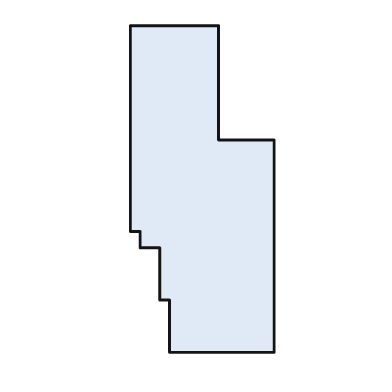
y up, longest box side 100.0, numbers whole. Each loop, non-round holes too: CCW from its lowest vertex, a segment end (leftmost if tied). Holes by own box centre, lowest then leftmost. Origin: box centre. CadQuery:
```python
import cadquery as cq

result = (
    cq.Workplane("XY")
    .moveTo(-10.0, -50.0)
    .lineTo(22.0, -50.0)
    .lineTo(22.0, 15.0)
    .lineTo(5.0, 15.0)
    .lineTo(5.0, 50.0)
    .lineTo(-22.0, 50.0)
    .lineTo(-22.0, -13.0)
    .lineTo(-19.0, -13.0)
    .lineTo(-19.0, -18.0)
    .lineTo(-13.0, -18.0)
    .lineTo(-13.0, -34.0)
    .lineTo(-10.0, -34.0)
    .close()
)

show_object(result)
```